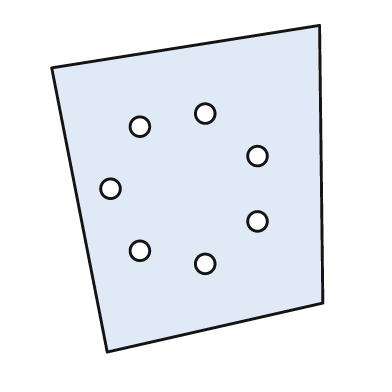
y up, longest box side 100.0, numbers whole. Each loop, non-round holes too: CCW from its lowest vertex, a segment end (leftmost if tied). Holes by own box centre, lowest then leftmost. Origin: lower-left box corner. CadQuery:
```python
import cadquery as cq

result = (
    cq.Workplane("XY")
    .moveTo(17.0, 0.0)
    .lineTo(83.0, 15.0)
    .lineTo(82.0, 100.0)
    .lineTo(0.0, 87.0)
    .close()
    .moveTo(47.0, 27.0)
    .circle(3.0)
    .moveTo(27.0, 31.0)
    .circle(3.0)
    .moveTo(63.0, 40.0)
    .circle(3.0)
    .moveTo(18.0, 50.0)
    .circle(3.0)
    .moveTo(63.0, 60.0)
    .circle(3.0)
    .moveTo(27.0, 69.0)
    .circle(3.0)
    .moveTo(47.0, 73.0)
    .circle(3.0)
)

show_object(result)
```